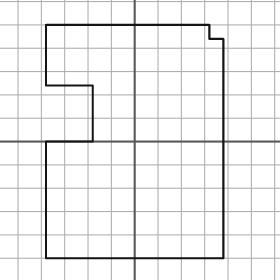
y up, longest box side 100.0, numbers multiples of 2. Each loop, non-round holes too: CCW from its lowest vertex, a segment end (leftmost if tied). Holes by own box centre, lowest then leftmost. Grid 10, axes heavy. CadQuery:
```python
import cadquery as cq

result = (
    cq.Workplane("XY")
    .moveTo(-38.0, -50.0)
    .lineTo(38.0, -50.0)
    .lineTo(38.0, 44.0)
    .lineTo(32.0, 44.0)
    .lineTo(32.0, 50.0)
    .lineTo(-38.0, 50.0)
    .lineTo(-38.0, 24.0)
    .lineTo(-18.0, 24.0)
    .lineTo(-18.0, 0.0)
    .lineTo(-38.0, 0.0)
    .close()
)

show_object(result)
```